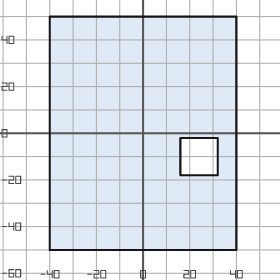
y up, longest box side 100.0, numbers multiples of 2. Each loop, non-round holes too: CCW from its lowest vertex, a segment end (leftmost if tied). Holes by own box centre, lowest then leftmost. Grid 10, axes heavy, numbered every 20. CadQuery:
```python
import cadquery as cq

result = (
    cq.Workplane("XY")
    .moveTo(-40.0, -50.0)
    .lineTo(40.0, -50.0)
    .lineTo(40.0, 50.0)
    .lineTo(-40.0, 50.0)
    .close()
    .moveTo(16.0, -18.0)
    .lineTo(32.0, -18.0)
    .lineTo(32.0, -2.0)
    .lineTo(16.0, -2.0)
    .close()
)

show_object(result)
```